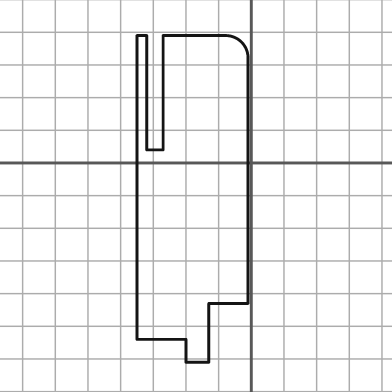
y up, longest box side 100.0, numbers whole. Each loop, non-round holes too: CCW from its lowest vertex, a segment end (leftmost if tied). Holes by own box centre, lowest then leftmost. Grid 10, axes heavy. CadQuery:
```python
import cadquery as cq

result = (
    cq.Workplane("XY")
    .moveTo(-20.0, -61.0)
    .lineTo(-13.0, -61.0)
    .lineTo(-13.0, -43.0)
    .lineTo(-1.0, -43.0)
    .lineTo(-1.0, 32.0)
    .threePointArc((-3.0, 37.0), (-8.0, 39.0))
    .lineTo(-27.0, 39.0)
    .lineTo(-27.0, 4.0)
    .lineTo(-32.0, 4.0)
    .lineTo(-32.0, 39.0)
    .lineTo(-35.0, 39.0)
    .lineTo(-35.0, -54.0)
    .lineTo(-20.0, -54.0)
    .close()
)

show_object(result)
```